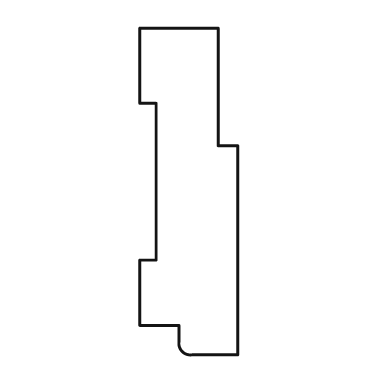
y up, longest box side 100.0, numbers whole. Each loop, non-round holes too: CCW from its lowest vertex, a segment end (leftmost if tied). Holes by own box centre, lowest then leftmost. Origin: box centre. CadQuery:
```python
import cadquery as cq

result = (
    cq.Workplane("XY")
    .moveTo(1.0, -50.0)
    .lineTo(15.0, -50.0)
    .lineTo(15.0, 14.0)
    .lineTo(9.0, 14.0)
    .lineTo(9.0, 50.0)
    .lineTo(-15.0, 50.0)
    .lineTo(-15.0, 27.0)
    .lineTo(-10.0, 27.0)
    .lineTo(-10.0, -21.0)
    .lineTo(-15.0, -21.0)
    .lineTo(-15.0, -41.0)
    .lineTo(-3.0, -41.0)
    .lineTo(-3.0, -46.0)
    .threePointArc((-2.0, -49.0), (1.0, -50.0))
    .close()
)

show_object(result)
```